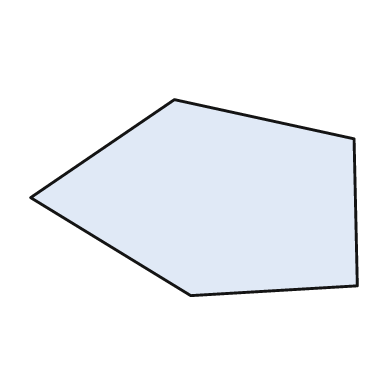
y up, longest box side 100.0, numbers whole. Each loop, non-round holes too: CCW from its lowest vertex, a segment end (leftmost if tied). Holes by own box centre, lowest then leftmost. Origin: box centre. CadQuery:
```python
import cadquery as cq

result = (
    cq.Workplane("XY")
    .moveTo(-1.0, -30.0)
    .lineTo(50.0, -27.0)
    .lineTo(49.0, 18.0)
    .lineTo(-6.0, 30.0)
    .lineTo(-50.0, 0.0)
    .close()
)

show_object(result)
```